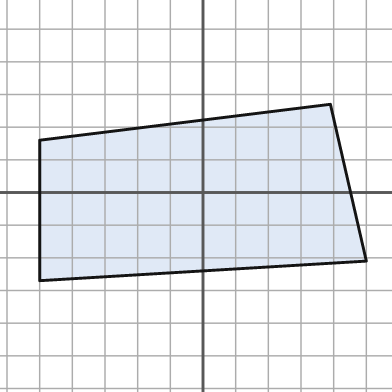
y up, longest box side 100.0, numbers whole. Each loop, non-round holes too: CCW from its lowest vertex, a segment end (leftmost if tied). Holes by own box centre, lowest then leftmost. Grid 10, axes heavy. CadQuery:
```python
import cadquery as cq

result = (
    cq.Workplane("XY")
    .moveTo(-50.0, -27.0)
    .lineTo(50.0, -21.0)
    .lineTo(39.0, 27.0)
    .lineTo(-50.0, 16.0)
    .close()
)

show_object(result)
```